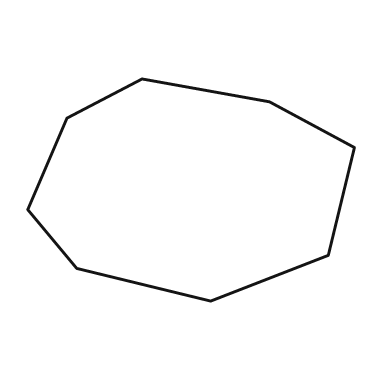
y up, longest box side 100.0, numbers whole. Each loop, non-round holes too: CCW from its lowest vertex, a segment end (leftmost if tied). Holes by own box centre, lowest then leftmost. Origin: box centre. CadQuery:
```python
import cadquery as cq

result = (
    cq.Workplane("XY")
    .moveTo(6.0, -34.0)
    .lineTo(42.0, -20.0)
    .lineTo(50.0, 13.0)
    .lineTo(24.0, 27.0)
    .lineTo(-15.0, 34.0)
    .lineTo(-38.0, 22.0)
    .lineTo(-50.0, -6.0)
    .lineTo(-35.0, -24.0)
    .close()
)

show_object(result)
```